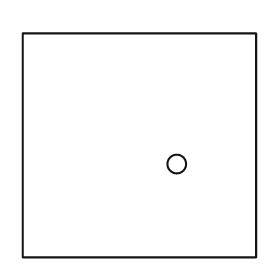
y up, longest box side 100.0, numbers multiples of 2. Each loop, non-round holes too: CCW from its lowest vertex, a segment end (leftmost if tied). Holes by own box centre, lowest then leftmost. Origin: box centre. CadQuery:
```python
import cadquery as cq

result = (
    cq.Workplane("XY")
    .moveTo(-50.0, -48.0)
    .lineTo(50.0, -48.0)
    .lineTo(50.0, 48.0)
    .lineTo(-50.0, 48.0)
    .close()
    .moveTo(16.0, -8.0)
    .circle(4.0)
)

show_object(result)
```